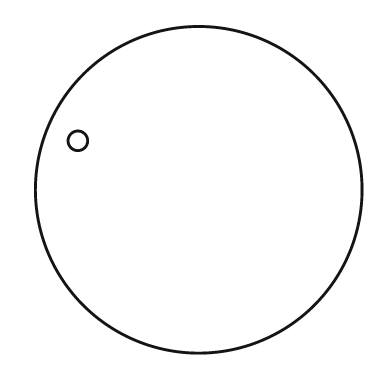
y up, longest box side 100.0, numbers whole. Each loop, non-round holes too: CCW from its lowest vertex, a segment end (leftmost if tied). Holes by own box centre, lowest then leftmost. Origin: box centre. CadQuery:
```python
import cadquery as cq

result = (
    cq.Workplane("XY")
    .moveTo(0.0, 0.0)
    .circle(50.0)
    .moveTo(-37.0, 15.0)
    .circle(3.0)
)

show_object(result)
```